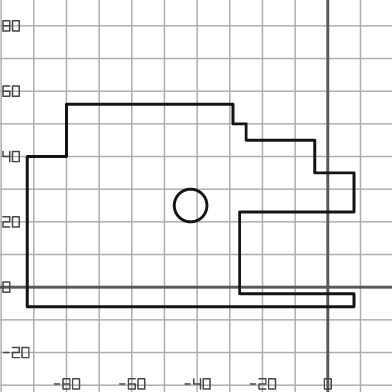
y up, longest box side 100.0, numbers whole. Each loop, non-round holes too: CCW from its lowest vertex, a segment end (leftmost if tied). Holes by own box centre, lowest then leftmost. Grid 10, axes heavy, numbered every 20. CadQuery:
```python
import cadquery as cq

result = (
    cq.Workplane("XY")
    .moveTo(-92.0, -6.0)
    .lineTo(8.0, -6.0)
    .lineTo(8.0, -2.0)
    .lineTo(-27.0, -2.0)
    .lineTo(-27.0, 23.0)
    .lineTo(8.0, 23.0)
    .lineTo(8.0, 35.0)
    .lineTo(-4.0, 35.0)
    .lineTo(-4.0, 45.0)
    .lineTo(-25.0, 45.0)
    .lineTo(-25.0, 50.0)
    .lineTo(-29.0, 50.0)
    .lineTo(-29.0, 56.0)
    .lineTo(-80.0, 56.0)
    .lineTo(-80.0, 40.0)
    .lineTo(-92.0, 40.0)
    .close()
    .moveTo(-42.0, 25.0)
    .circle(5.0)
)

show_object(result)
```